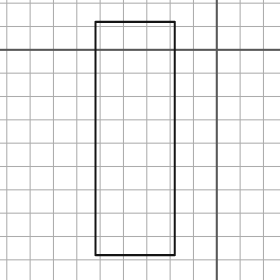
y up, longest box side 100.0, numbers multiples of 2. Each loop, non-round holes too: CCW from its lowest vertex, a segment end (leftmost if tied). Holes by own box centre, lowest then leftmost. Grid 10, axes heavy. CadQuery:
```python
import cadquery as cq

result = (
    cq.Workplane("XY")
    .moveTo(-52.0, -88.0)
    .lineTo(-18.0, -88.0)
    .lineTo(-18.0, 12.0)
    .lineTo(-52.0, 12.0)
    .close()
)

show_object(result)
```